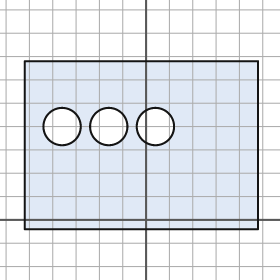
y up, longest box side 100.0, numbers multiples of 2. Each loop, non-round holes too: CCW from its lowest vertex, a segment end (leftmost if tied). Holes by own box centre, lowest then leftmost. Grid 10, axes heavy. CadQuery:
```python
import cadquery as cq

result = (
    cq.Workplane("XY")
    .moveTo(-52.0, -4.0)
    .lineTo(48.0, -4.0)
    .lineTo(48.0, 68.0)
    .lineTo(-52.0, 68.0)
    .close()
    .moveTo(-36.0, 40.0)
    .circle(8.0)
    .moveTo(-16.0, 40.0)
    .circle(8.0)
    .moveTo(4.0, 40.0)
    .circle(8.0)
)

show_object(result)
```